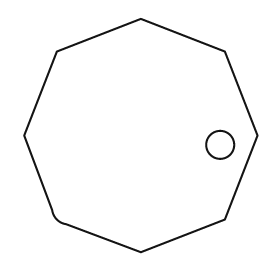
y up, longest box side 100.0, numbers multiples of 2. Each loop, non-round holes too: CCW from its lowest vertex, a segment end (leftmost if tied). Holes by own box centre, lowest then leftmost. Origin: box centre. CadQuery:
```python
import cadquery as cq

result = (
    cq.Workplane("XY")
    .moveTo(0.0, -50.0)
    .lineTo(36.0, -36.0)
    .lineTo(50.0, 0.0)
    .lineTo(36.0, 36.0)
    .lineTo(0.0, 50.0)
    .lineTo(-36.0, 36.0)
    .lineTo(-50.0, 0.0)
    .lineTo(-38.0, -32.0)
    .threePointArc((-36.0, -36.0), (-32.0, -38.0))
    .close()
    .moveTo(34.0, -4.0)
    .circle(6.0)
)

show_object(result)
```